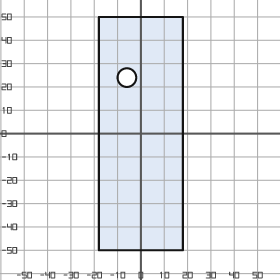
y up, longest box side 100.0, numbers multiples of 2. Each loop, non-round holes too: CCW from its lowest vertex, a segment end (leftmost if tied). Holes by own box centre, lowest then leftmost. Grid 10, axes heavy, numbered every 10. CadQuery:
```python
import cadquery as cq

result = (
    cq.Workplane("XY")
    .moveTo(-18.0, -50.0)
    .lineTo(18.0, -50.0)
    .lineTo(18.0, 50.0)
    .lineTo(-18.0, 50.0)
    .close()
    .moveTo(-6.0, 24.0)
    .circle(4.0)
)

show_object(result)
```